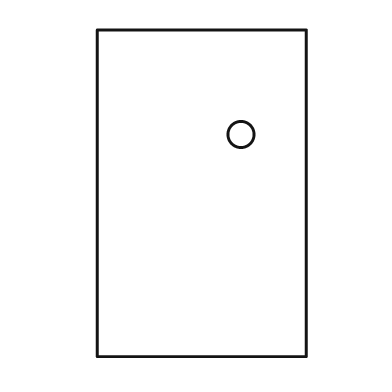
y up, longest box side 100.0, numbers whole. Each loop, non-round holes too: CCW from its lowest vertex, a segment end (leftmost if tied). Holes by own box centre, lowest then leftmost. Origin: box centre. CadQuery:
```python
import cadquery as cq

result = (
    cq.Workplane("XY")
    .moveTo(-32.0, -50.0)
    .lineTo(32.0, -50.0)
    .lineTo(32.0, 50.0)
    .lineTo(-32.0, 50.0)
    .close()
    .moveTo(12.0, 18.0)
    .circle(4.0)
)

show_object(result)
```